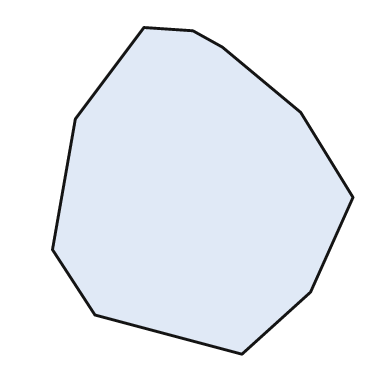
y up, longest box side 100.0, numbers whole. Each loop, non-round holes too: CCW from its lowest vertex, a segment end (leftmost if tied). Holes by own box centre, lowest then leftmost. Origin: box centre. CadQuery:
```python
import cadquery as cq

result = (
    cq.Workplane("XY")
    .moveTo(12.0, -50.0)
    .lineTo(33.0, -31.0)
    .lineTo(46.0, -2.0)
    .lineTo(30.0, 24.0)
    .lineTo(6.0, 44.0)
    .lineTo(-3.0, 49.0)
    .lineTo(-18.0, 50.0)
    .lineTo(-39.0, 22.0)
    .lineTo(-46.0, -18.0)
    .lineTo(-33.0, -38.0)
    .close()
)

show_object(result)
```